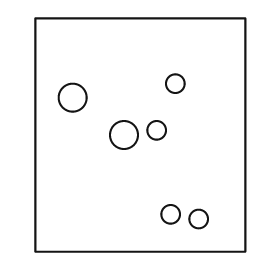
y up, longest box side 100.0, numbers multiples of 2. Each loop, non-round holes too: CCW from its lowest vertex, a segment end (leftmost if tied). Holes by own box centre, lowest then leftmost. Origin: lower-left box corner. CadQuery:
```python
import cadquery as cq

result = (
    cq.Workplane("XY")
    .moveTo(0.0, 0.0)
    .lineTo(90.0, 0.0)
    .lineTo(90.0, 100.0)
    .lineTo(0.0, 100.0)
    .close()
    .moveTo(70.0, 14.0)
    .circle(4.0)
    .moveTo(58.0, 16.0)
    .circle(4.0)
    .moveTo(38.0, 50.0)
    .circle(6.0)
    .moveTo(52.0, 52.0)
    .circle(4.0)
    .moveTo(16.0, 66.0)
    .circle(6.0)
    .moveTo(60.0, 72.0)
    .circle(4.0)
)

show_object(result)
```